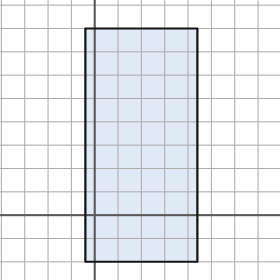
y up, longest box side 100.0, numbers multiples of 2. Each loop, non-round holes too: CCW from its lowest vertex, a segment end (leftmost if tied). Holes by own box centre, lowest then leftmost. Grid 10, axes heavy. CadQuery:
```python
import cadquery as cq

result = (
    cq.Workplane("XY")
    .moveTo(-4.0, -20.0)
    .lineTo(44.0, -20.0)
    .lineTo(44.0, 80.0)
    .lineTo(-4.0, 80.0)
    .close()
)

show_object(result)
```